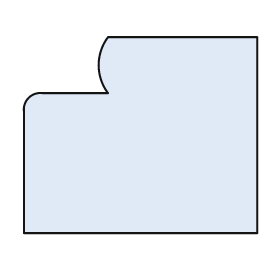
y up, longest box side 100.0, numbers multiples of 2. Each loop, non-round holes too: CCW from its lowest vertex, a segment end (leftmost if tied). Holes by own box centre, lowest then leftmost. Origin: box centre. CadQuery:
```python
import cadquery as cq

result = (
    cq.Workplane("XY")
    .moveTo(-50.0, -42.0)
    .lineTo(50.0, -42.0)
    .lineTo(50.0, 42.0)
    .lineTo(-14.0, 42.0)
    .threePointArc((-18.0, 30.0), (-14.0, 18.0))
    .lineTo(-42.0, 18.0)
    .threePointArc((-48.0, 16.0), (-50.0, 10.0))
    .close()
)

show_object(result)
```